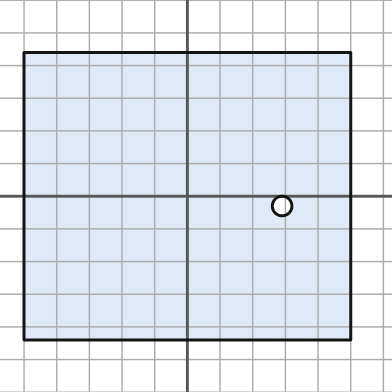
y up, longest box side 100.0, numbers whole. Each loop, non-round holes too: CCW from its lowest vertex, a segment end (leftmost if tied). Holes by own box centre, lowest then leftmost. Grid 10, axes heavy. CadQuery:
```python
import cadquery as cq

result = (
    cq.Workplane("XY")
    .moveTo(-50.0, -44.0)
    .lineTo(50.0, -44.0)
    .lineTo(50.0, 44.0)
    .lineTo(-50.0, 44.0)
    .close()
    .moveTo(29.0, -3.0)
    .circle(3.0)
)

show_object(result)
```